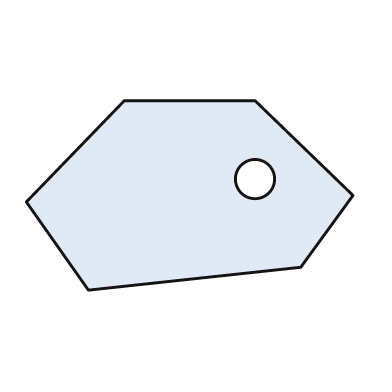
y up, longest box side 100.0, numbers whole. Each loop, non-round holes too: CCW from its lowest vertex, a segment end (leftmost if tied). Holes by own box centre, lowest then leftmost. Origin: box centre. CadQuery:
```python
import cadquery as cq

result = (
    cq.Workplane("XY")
    .moveTo(-31.0, -29.0)
    .lineTo(34.0, -22.0)
    .lineTo(50.0, 0.0)
    .lineTo(20.0, 29.0)
    .lineTo(-20.0, 29.0)
    .lineTo(-50.0, -2.0)
    .close()
    .moveTo(20.0, 5.0)
    .circle(6.0)
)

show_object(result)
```